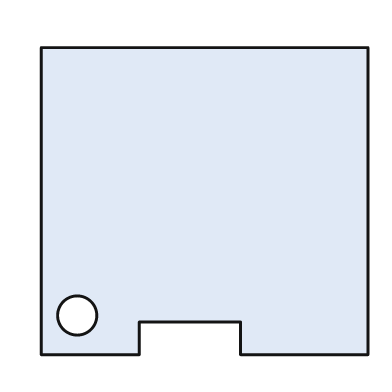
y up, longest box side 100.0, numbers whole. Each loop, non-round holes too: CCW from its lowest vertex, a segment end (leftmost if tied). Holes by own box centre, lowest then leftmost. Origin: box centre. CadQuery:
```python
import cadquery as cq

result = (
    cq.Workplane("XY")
    .moveTo(-50.0, -47.0)
    .lineTo(-20.0, -47.0)
    .lineTo(-20.0, -37.0)
    .lineTo(11.0, -37.0)
    .lineTo(11.0, -47.0)
    .lineTo(50.0, -47.0)
    .lineTo(50.0, 47.0)
    .lineTo(-50.0, 47.0)
    .close()
    .moveTo(-39.0, -35.0)
    .circle(6.0)
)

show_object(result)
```